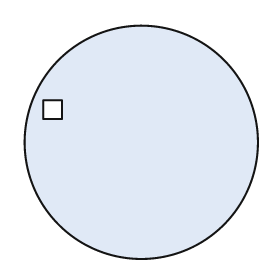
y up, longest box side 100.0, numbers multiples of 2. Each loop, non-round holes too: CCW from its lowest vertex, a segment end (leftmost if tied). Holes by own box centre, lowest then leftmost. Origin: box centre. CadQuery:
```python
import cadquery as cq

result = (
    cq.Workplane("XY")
    .moveTo(0.0, 0.0)
    .circle(50.0)
    .moveTo(-42.0, 10.0)
    .lineTo(-34.0, 10.0)
    .lineTo(-34.0, 18.0)
    .lineTo(-42.0, 18.0)
    .close()
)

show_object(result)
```